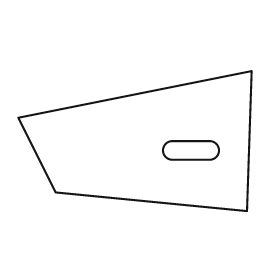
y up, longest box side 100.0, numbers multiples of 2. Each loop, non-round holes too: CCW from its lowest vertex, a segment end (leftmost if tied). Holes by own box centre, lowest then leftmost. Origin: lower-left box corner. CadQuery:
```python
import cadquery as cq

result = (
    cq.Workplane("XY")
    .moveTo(98.0, 0.0)
    .lineTo(100.0, 60.0)
    .lineTo(0.0, 40.0)
    .lineTo(16.0, 8.0)
    .close()
    .moveTo(66.0, 22.0)
    .lineTo(82.0, 22.0)
    .threePointArc((86.0, 26.0), (82.0, 30.0))
    .lineTo(66.0, 30.0)
    .threePointArc((62.0, 26.0), (66.0, 22.0))
    .close()
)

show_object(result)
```